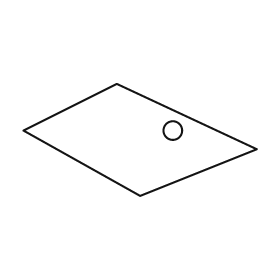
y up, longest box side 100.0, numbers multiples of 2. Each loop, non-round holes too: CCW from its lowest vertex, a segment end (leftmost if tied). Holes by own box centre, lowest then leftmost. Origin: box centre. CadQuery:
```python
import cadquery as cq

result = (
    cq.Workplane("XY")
    .moveTo(0.0, -24.0)
    .lineTo(50.0, -4.0)
    .lineTo(-10.0, 24.0)
    .lineTo(-50.0, 4.0)
    .close()
    .moveTo(14.0, 4.0)
    .circle(4.0)
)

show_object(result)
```